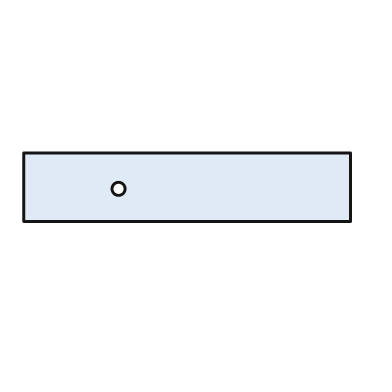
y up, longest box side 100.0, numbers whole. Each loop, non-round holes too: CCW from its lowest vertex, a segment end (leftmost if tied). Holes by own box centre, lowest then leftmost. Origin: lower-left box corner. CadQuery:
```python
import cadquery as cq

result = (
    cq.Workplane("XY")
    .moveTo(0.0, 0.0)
    .lineTo(100.0, 0.0)
    .lineTo(100.0, 21.0)
    .lineTo(0.0, 21.0)
    .close()
    .moveTo(29.0, 10.0)
    .circle(2.0)
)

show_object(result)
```